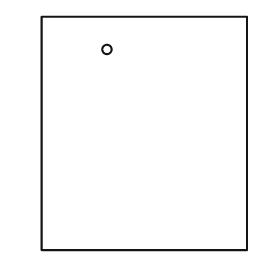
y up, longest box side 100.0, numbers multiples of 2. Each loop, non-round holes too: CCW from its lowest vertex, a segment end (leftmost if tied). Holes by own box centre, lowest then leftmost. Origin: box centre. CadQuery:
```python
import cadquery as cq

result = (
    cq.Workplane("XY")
    .moveTo(-44.0, -50.0)
    .lineTo(44.0, -50.0)
    .lineTo(44.0, 50.0)
    .lineTo(-44.0, 50.0)
    .close()
    .moveTo(-16.0, 36.0)
    .circle(2.0)
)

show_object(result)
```